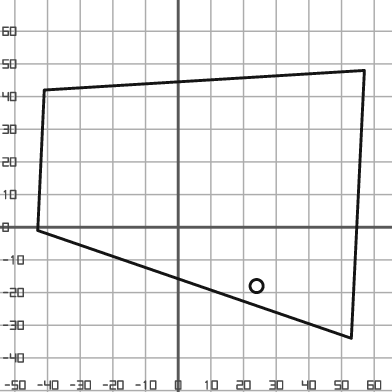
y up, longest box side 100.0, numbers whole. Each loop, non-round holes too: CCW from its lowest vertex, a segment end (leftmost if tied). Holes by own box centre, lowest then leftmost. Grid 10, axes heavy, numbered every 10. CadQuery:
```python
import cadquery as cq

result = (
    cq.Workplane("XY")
    .moveTo(53.0, -34.0)
    .lineTo(57.0, 48.0)
    .lineTo(-41.0, 42.0)
    .lineTo(-43.0, -1.0)
    .close()
    .moveTo(24.0, -18.0)
    .circle(2.0)
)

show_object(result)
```